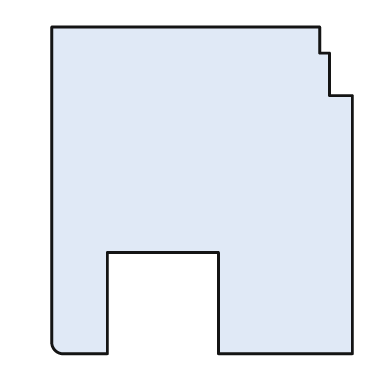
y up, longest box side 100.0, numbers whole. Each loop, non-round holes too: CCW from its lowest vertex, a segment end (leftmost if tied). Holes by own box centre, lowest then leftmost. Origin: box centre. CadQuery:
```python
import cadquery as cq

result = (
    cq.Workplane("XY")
    .moveTo(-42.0, -50.0)
    .lineTo(-29.0, -50.0)
    .lineTo(-29.0, -19.0)
    .lineTo(5.0, -19.0)
    .lineTo(5.0, -50.0)
    .lineTo(46.0, -50.0)
    .lineTo(46.0, 29.0)
    .lineTo(39.0, 29.0)
    .lineTo(39.0, 42.0)
    .lineTo(36.0, 42.0)
    .lineTo(36.0, 50.0)
    .lineTo(-46.0, 50.0)
    .lineTo(-46.0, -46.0)
    .threePointArc((-45.0, -49.0), (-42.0, -50.0))
    .close()
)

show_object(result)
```